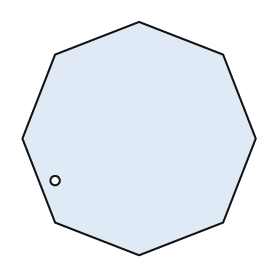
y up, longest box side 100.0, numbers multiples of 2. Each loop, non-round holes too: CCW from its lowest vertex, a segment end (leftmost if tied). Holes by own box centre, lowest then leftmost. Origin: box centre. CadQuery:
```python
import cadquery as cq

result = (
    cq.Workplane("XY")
    .moveTo(0.0, -50.0)
    .lineTo(36.0, -36.0)
    .lineTo(50.0, 0.0)
    .lineTo(36.0, 36.0)
    .lineTo(0.0, 50.0)
    .lineTo(-36.0, 36.0)
    .lineTo(-50.0, 0.0)
    .lineTo(-36.0, -36.0)
    .close()
    .moveTo(-36.0, -18.0)
    .circle(2.0)
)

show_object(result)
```